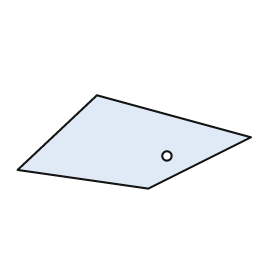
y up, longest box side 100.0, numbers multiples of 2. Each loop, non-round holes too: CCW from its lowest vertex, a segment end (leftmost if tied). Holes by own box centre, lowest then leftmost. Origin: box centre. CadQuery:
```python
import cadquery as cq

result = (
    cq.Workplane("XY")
    .moveTo(6.0, -20.0)
    .lineTo(50.0, 2.0)
    .lineTo(-16.0, 20.0)
    .lineTo(-50.0, -12.0)
    .close()
    .moveTo(14.0, -6.0)
    .circle(2.0)
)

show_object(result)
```